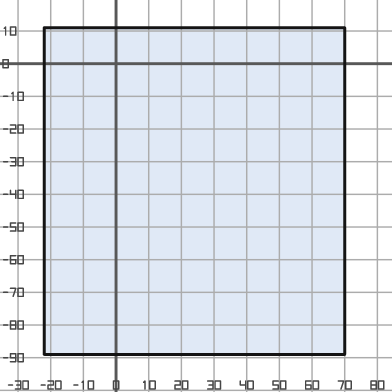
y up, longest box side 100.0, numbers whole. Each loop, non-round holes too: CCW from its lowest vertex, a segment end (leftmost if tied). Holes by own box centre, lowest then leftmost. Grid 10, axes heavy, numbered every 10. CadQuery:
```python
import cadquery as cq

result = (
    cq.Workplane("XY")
    .moveTo(-22.0, -89.0)
    .lineTo(70.0, -89.0)
    .lineTo(70.0, 11.0)
    .lineTo(-22.0, 11.0)
    .close()
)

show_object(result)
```